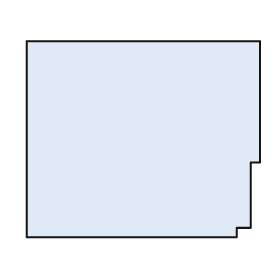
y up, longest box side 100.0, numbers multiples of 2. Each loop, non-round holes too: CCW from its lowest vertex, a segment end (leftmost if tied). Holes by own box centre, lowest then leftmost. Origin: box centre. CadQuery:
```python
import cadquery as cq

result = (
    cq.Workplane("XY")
    .moveTo(-50.0, -42.0)
    .lineTo(40.0, -42.0)
    .lineTo(40.0, -38.0)
    .lineTo(46.0, -38.0)
    .lineTo(46.0, -10.0)
    .lineTo(50.0, -10.0)
    .lineTo(50.0, 42.0)
    .lineTo(-50.0, 42.0)
    .close()
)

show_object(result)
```